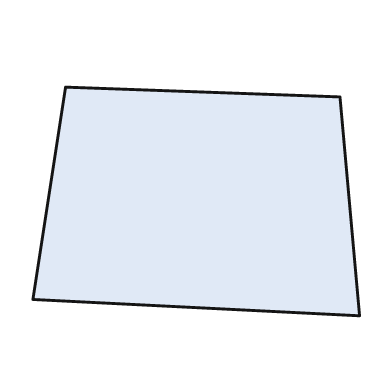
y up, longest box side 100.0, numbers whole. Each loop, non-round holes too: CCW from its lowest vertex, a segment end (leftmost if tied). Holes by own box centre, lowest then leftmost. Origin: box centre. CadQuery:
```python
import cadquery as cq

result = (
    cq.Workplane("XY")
    .moveTo(50.0, -35.0)
    .lineTo(44.0, 32.0)
    .lineTo(-40.0, 35.0)
    .lineTo(-50.0, -30.0)
    .close()
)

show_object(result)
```